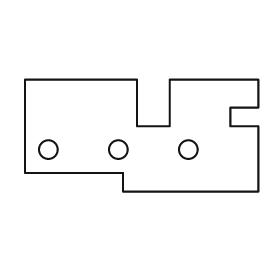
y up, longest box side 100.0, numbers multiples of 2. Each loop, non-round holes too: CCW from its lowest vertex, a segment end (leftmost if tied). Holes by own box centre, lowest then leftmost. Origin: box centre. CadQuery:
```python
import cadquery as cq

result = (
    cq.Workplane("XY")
    .moveTo(-8.0, -24.0)
    .lineTo(50.0, -24.0)
    .lineTo(50.0, 4.0)
    .lineTo(38.0, 4.0)
    .lineTo(38.0, 12.0)
    .lineTo(50.0, 12.0)
    .lineTo(50.0, 24.0)
    .lineTo(12.0, 24.0)
    .lineTo(12.0, 4.0)
    .lineTo(-2.0, 4.0)
    .lineTo(-2.0, 24.0)
    .lineTo(-50.0, 24.0)
    .lineTo(-50.0, -16.0)
    .lineTo(-8.0, -16.0)
    .close()
    .moveTo(-40.0, -6.0)
    .circle(4.0)
    .moveTo(-10.0, -6.0)
    .circle(4.0)
    .moveTo(20.0, -6.0)
    .circle(4.0)
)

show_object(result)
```